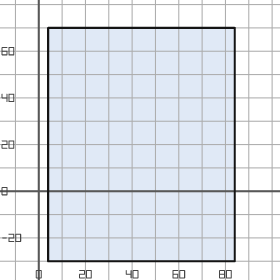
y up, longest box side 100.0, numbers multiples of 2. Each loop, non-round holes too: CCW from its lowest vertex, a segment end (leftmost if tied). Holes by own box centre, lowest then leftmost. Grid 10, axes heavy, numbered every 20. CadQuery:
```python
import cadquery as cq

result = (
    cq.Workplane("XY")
    .moveTo(4.0, -30.0)
    .lineTo(84.0, -30.0)
    .lineTo(84.0, 70.0)
    .lineTo(4.0, 70.0)
    .close()
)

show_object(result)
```